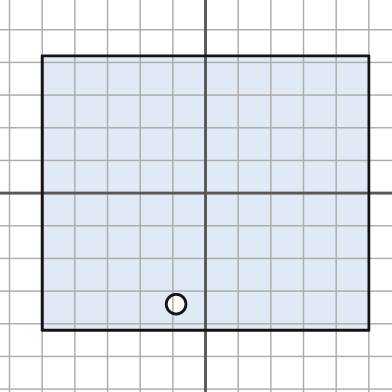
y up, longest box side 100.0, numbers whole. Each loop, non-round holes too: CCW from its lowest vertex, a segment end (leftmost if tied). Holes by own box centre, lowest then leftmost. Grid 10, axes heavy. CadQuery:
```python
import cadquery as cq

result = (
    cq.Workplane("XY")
    .moveTo(-50.0, -42.0)
    .lineTo(50.0, -42.0)
    .lineTo(50.0, 42.0)
    .lineTo(-50.0, 42.0)
    .close()
    .moveTo(-9.0, -34.0)
    .circle(3.0)
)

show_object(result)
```